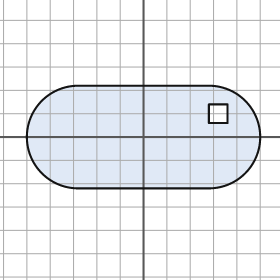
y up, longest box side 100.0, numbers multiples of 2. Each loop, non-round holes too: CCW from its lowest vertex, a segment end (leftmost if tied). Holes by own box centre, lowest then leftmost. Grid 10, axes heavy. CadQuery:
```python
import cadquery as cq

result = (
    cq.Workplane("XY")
    .moveTo(-28.0, -22.0)
    .lineTo(28.0, -22.0)
    .threePointArc((50.0, 0.0), (28.0, 22.0))
    .lineTo(-28.0, 22.0)
    .threePointArc((-50.0, 0.0), (-28.0, -22.0))
    .close()
    .moveTo(28.0, 6.0)
    .lineTo(36.0, 6.0)
    .lineTo(36.0, 14.0)
    .lineTo(28.0, 14.0)
    .close()
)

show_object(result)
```